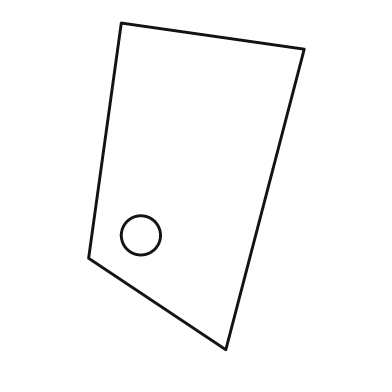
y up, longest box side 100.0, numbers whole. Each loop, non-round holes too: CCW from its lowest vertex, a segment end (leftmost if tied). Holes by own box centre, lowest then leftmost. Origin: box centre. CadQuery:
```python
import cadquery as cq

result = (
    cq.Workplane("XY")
    .moveTo(9.0, -50.0)
    .lineTo(33.0, 42.0)
    .lineTo(-23.0, 50.0)
    .lineTo(-33.0, -22.0)
    .close()
    .moveTo(-17.0, -15.0)
    .circle(6.0)
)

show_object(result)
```